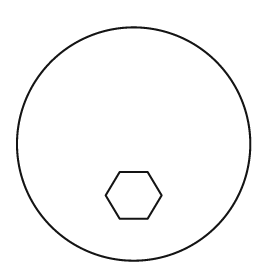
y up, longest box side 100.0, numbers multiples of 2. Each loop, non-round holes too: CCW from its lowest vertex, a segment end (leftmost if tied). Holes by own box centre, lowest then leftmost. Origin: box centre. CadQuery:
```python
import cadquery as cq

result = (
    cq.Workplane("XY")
    .moveTo(0.0, 0.0)
    .circle(50.0)
    .moveTo(-6.0, -32.0)
    .lineTo(6.0, -32.0)
    .lineTo(12.0, -22.0)
    .lineTo(6.0, -12.0)
    .lineTo(-6.0, -12.0)
    .lineTo(-12.0, -22.0)
    .close()
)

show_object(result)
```